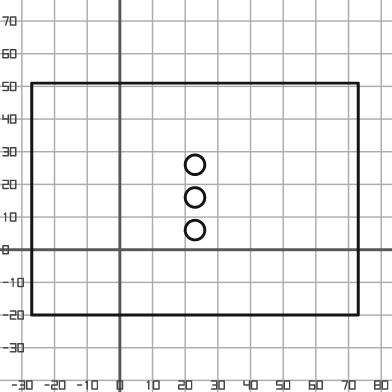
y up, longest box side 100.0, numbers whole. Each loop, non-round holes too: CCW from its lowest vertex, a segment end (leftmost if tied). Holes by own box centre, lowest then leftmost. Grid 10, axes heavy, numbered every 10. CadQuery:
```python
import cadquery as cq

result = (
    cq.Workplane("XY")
    .moveTo(-27.0, -20.0)
    .lineTo(73.0, -20.0)
    .lineTo(73.0, 51.0)
    .lineTo(-27.0, 51.0)
    .close()
    .moveTo(23.0, 6.0)
    .circle(3.0)
    .moveTo(23.0, 16.0)
    .circle(3.0)
    .moveTo(23.0, 26.0)
    .circle(3.0)
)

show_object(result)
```